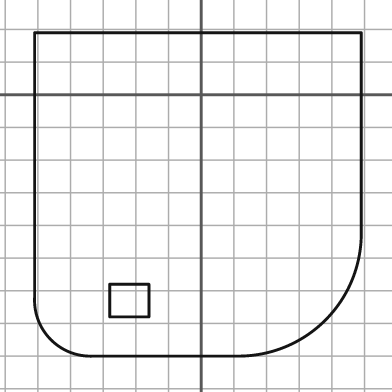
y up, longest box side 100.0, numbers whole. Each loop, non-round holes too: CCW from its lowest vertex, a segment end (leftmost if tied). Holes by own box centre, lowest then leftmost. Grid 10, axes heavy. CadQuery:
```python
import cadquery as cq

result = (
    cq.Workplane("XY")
    .moveTo(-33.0, -80.0)
    .lineTo(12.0, -80.0)
    .threePointArc((38.0, -69.0), (49.0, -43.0))
    .lineTo(49.0, 19.0)
    .lineTo(-51.0, 19.0)
    .lineTo(-51.0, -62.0)
    .threePointArc((-46.0, -75.0), (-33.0, -80.0))
    .close()
    .moveTo(-28.0, -68.0)
    .lineTo(-16.0, -68.0)
    .lineTo(-16.0, -58.0)
    .lineTo(-28.0, -58.0)
    .close()
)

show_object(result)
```